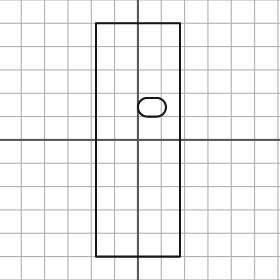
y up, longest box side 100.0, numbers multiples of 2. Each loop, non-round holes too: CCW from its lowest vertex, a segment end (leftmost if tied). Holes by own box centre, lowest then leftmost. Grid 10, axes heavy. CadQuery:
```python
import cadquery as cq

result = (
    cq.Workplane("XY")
    .moveTo(-18.0, -50.0)
    .lineTo(18.0, -50.0)
    .lineTo(18.0, 50.0)
    .lineTo(-18.0, 50.0)
    .close()
    .moveTo(4.0, 10.0)
    .lineTo(8.0, 10.0)
    .threePointArc((12.0, 14.0), (8.0, 18.0))
    .lineTo(4.0, 18.0)
    .threePointArc((0.0, 14.0), (4.0, 10.0))
    .close()
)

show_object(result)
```